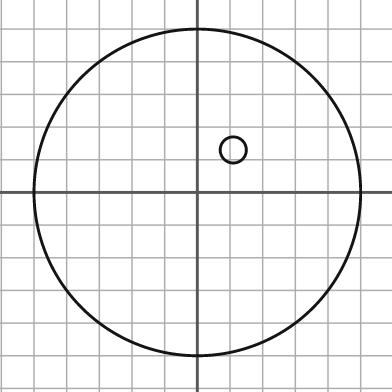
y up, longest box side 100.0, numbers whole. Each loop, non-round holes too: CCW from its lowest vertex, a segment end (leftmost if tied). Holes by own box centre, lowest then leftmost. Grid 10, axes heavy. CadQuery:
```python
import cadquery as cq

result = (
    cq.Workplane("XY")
    .moveTo(0.0, 0.0)
    .circle(50.0)
    .moveTo(11.0, 13.0)
    .circle(4.0)
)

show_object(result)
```